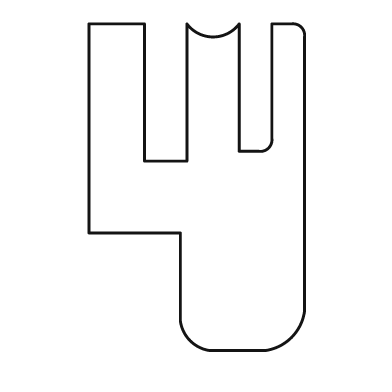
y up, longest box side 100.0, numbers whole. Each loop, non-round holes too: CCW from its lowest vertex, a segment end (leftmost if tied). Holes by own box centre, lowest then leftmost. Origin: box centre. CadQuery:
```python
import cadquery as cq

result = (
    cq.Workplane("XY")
    .moveTo(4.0, -50.0)
    .lineTo(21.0, -50.0)
    .threePointArc((29.0, -46.0), (33.0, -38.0))
    .lineTo(33.0, 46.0)
    .threePointArc((32.0, 49.0), (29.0, 50.0))
    .lineTo(23.0, 50.0)
    .lineTo(23.0, 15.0)
    .threePointArc((22.0, 12.0), (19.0, 11.0))
    .lineTo(13.0, 11.0)
    .lineTo(13.0, 50.0)
    .threePointArc((5.0, 46.0), (-3.0, 50.0))
    .lineTo(-3.0, 8.0)
    .lineTo(-16.0, 8.0)
    .lineTo(-16.0, 50.0)
    .lineTo(-33.0, 50.0)
    .lineTo(-33.0, -14.0)
    .lineTo(-5.0, -14.0)
    .lineTo(-5.0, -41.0)
    .threePointArc((-2.0, -47.0), (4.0, -50.0))
    .close()
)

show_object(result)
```